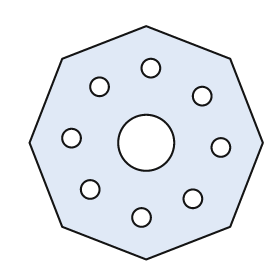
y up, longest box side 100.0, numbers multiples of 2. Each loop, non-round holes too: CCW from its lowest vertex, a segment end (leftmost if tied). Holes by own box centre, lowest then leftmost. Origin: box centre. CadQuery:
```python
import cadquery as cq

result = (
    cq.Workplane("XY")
    .moveTo(0.0, -50.0)
    .lineTo(36.0, -36.0)
    .lineTo(50.0, 0.0)
    .lineTo(36.0, 36.0)
    .lineTo(0.0, 50.0)
    .lineTo(-36.0, 36.0)
    .lineTo(-50.0, 0.0)
    .lineTo(-36.0, -36.0)
    .close()
    .moveTo(-2.0, -32.0)
    .circle(4.0)
    .moveTo(20.0, -24.0)
    .circle(4.0)
    .moveTo(-24.0, -20.0)
    .circle(4.0)
    .moveTo(32.0, -2.0)
    .circle(4.0)
    .moveTo(0.0, 0.0)
    .circle(12.0)
    .moveTo(-32.0, 2.0)
    .circle(4.0)
    .moveTo(24.0, 20.0)
    .circle(4.0)
    .moveTo(-20.0, 24.0)
    .circle(4.0)
    .moveTo(2.0, 32.0)
    .circle(4.0)
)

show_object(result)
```